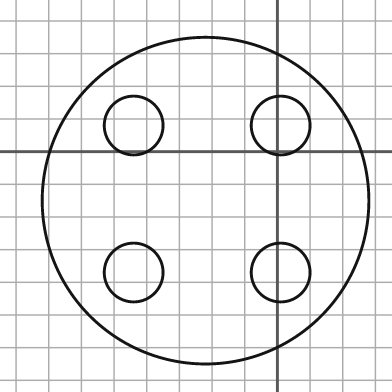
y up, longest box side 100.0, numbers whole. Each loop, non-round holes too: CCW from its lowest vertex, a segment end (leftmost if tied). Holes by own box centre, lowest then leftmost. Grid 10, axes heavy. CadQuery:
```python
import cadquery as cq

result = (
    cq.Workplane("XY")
    .moveTo(-22.0, -15.0)
    .circle(50.0)
    .moveTo(-44.0, -37.0)
    .circle(9.0)
    .moveTo(1.0, -37.0)
    .circle(9.0)
    .moveTo(-44.0, 8.0)
    .circle(9.0)
    .moveTo(1.0, 8.0)
    .circle(9.0)
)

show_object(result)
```